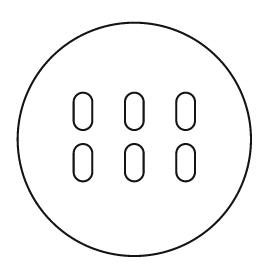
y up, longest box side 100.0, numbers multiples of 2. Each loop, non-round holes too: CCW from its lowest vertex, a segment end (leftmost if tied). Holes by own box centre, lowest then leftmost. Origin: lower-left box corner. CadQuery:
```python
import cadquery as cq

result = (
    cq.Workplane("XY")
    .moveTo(50.0, 50.0)
    .circle(50.0)
    .moveTo(24.0, 36.0)
    .threePointArc((28.0, 32.0), (32.0, 36.0))
    .lineTo(32.0, 44.0)
    .threePointArc((28.0, 48.0), (24.0, 44.0))
    .close()
    .moveTo(46.0, 36.0)
    .threePointArc((50.0, 32.0), (54.0, 36.0))
    .lineTo(54.0, 44.0)
    .threePointArc((50.0, 48.0), (46.0, 44.0))
    .close()
    .moveTo(68.0, 36.0)
    .threePointArc((72.0, 32.0), (76.0, 36.0))
    .lineTo(76.0, 44.0)
    .threePointArc((72.0, 48.0), (68.0, 44.0))
    .close()
    .moveTo(24.0, 58.0)
    .threePointArc((28.0, 54.0), (32.0, 58.0))
    .lineTo(32.0, 66.0)
    .threePointArc((28.0, 70.0), (24.0, 66.0))
    .close()
    .moveTo(46.0, 58.0)
    .threePointArc((50.0, 54.0), (54.0, 58.0))
    .lineTo(54.0, 66.0)
    .threePointArc((50.0, 70.0), (46.0, 66.0))
    .close()
    .moveTo(68.0, 58.0)
    .threePointArc((72.0, 54.0), (76.0, 58.0))
    .lineTo(76.0, 66.0)
    .threePointArc((72.0, 70.0), (68.0, 66.0))
    .close()
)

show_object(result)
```